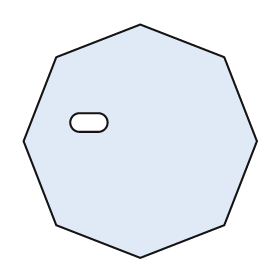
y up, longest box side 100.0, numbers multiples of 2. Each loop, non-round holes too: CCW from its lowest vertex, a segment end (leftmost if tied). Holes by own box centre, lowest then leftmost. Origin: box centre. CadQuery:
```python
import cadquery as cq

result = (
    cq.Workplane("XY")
    .moveTo(0.0, -50.0)
    .lineTo(36.0, -36.0)
    .lineTo(50.0, 0.0)
    .lineTo(36.0, 36.0)
    .lineTo(0.0, 50.0)
    .lineTo(-36.0, 36.0)
    .lineTo(-50.0, 0.0)
    .lineTo(-36.0, -36.0)
    .close()
    .moveTo(-26.0, 4.0)
    .lineTo(-18.0, 4.0)
    .threePointArc((-14.0, 8.0), (-18.0, 12.0))
    .lineTo(-26.0, 12.0)
    .threePointArc((-30.0, 8.0), (-26.0, 4.0))
    .close()
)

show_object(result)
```